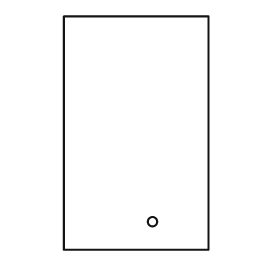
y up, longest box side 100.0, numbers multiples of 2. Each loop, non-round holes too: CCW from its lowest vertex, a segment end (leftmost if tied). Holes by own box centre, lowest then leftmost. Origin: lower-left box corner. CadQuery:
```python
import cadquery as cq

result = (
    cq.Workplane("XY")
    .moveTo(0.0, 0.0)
    .lineTo(62.0, 0.0)
    .lineTo(62.0, 100.0)
    .lineTo(0.0, 100.0)
    .close()
    .moveTo(38.0, 12.0)
    .circle(2.0)
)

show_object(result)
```